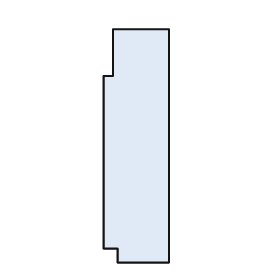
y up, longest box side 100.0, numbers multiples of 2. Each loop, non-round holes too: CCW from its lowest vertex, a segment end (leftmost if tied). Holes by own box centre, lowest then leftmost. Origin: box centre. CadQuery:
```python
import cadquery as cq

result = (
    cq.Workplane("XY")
    .moveTo(-8.0, -50.0)
    .lineTo(14.0, -50.0)
    .lineTo(14.0, 50.0)
    .lineTo(-10.0, 50.0)
    .lineTo(-10.0, 30.0)
    .lineTo(-14.0, 30.0)
    .lineTo(-14.0, -44.0)
    .lineTo(-8.0, -44.0)
    .close()
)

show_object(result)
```